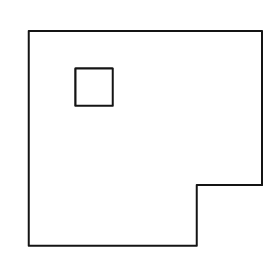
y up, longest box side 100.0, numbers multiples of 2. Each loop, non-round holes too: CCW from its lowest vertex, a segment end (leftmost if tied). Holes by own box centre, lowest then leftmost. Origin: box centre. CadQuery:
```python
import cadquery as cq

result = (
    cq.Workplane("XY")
    .moveTo(-50.0, -46.0)
    .lineTo(22.0, -46.0)
    .lineTo(22.0, -20.0)
    .lineTo(50.0, -20.0)
    .lineTo(50.0, 46.0)
    .lineTo(-50.0, 46.0)
    .close()
    .moveTo(-30.0, 14.0)
    .lineTo(-14.0, 14.0)
    .lineTo(-14.0, 30.0)
    .lineTo(-30.0, 30.0)
    .close()
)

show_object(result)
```